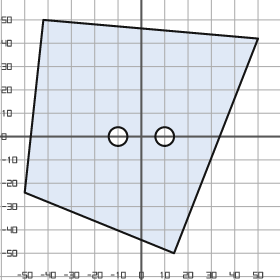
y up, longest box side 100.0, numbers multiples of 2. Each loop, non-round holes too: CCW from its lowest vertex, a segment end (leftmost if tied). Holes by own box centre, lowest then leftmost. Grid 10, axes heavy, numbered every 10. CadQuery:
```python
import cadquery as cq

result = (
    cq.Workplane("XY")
    .moveTo(14.0, -50.0)
    .lineTo(50.0, 42.0)
    .lineTo(-42.0, 50.0)
    .lineTo(-50.0, -24.0)
    .close()
    .moveTo(-10.0, 0.0)
    .circle(4.0)
    .moveTo(10.0, 0.0)
    .circle(4.0)
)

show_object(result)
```